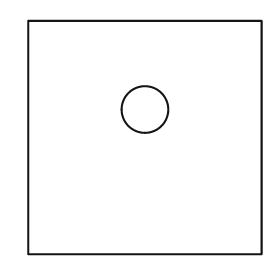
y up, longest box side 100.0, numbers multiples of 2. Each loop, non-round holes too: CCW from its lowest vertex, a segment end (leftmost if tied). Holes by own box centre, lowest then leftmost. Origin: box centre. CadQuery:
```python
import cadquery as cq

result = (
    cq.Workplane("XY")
    .moveTo(-50.0, -50.0)
    .lineTo(50.0, -50.0)
    .lineTo(50.0, 50.0)
    .lineTo(-50.0, 50.0)
    .close()
    .moveTo(0.0, 12.0)
    .circle(10.0)
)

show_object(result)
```